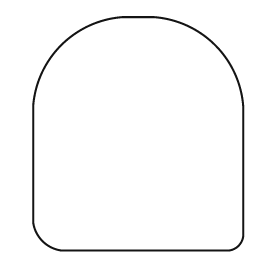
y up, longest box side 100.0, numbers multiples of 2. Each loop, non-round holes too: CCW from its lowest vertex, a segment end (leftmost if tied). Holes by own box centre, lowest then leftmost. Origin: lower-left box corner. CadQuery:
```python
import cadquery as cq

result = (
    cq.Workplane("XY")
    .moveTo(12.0, 0.0)
    .lineTo(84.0, 0.0)
    .threePointArc((88.0, 2.0), (90.0, 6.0))
    .lineTo(90.0, 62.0)
    .threePointArc((78.0, 88.0), (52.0, 100.0))
    .lineTo(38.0, 100.0)
    .threePointArc((12.0, 88.0), (0.0, 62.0))
    .lineTo(0.0, 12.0)
    .threePointArc((4.0, 4.0), (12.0, 0.0))
    .close()
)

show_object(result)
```